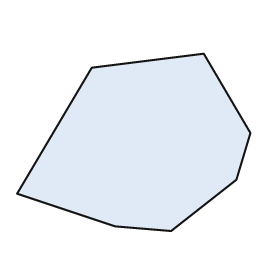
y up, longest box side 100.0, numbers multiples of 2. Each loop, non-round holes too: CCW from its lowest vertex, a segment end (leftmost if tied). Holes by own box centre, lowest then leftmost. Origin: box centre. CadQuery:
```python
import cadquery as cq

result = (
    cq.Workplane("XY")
    .moveTo(16.0, -38.0)
    .lineTo(44.0, -16.0)
    .lineTo(50.0, 4.0)
    .lineTo(30.0, 38.0)
    .lineTo(-18.0, 32.0)
    .lineTo(-50.0, -22.0)
    .lineTo(-8.0, -36.0)
    .close()
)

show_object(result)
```